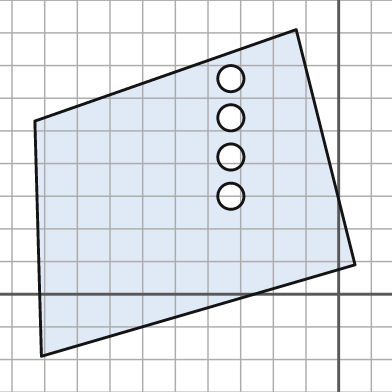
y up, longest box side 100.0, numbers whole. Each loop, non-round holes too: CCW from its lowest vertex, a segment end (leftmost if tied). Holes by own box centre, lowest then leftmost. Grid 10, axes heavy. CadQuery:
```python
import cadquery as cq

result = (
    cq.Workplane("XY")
    .moveTo(-91.0, -19.0)
    .lineTo(5.0, 9.0)
    .lineTo(-13.0, 81.0)
    .lineTo(-93.0, 53.0)
    .close()
    .moveTo(-33.0, 30.0)
    .circle(4.0)
    .moveTo(-33.0, 42.0)
    .circle(4.0)
    .moveTo(-33.0, 54.0)
    .circle(4.0)
    .moveTo(-33.0, 66.0)
    .circle(4.0)
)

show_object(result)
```